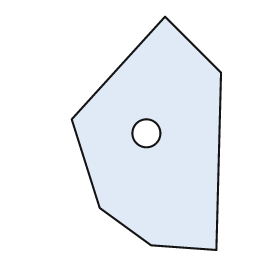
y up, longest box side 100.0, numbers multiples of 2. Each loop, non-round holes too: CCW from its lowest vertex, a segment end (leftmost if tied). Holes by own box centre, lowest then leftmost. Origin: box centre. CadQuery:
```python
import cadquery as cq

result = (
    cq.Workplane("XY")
    .moveTo(30.0, -50.0)
    .lineTo(32.0, 26.0)
    .lineTo(8.0, 50.0)
    .lineTo(-32.0, 6.0)
    .lineTo(-20.0, -32.0)
    .lineTo(2.0, -48.0)
    .close()
    .moveTo(0.0, 0.0)
    .circle(6.0)
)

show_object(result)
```